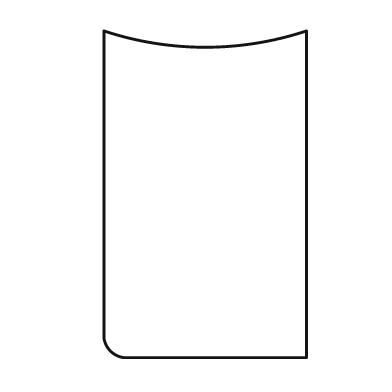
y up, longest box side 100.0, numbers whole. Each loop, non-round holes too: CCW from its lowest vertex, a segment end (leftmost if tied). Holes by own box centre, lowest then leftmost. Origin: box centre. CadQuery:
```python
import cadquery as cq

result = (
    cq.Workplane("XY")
    .moveTo(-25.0, -50.0)
    .lineTo(31.0, -50.0)
    .lineTo(31.0, 50.0)
    .threePointArc((0.0, 45.0), (-31.0, 50.0))
    .lineTo(-31.0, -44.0)
    .threePointArc((-29.0, -48.0), (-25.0, -50.0))
    .close()
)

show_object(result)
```